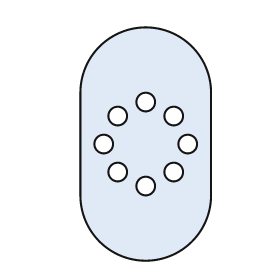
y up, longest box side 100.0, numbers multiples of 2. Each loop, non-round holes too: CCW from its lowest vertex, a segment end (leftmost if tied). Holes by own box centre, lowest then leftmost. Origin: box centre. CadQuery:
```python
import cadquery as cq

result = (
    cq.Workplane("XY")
    .moveTo(-28.0, -22.0)
    .threePointArc((0.0, -50.0), (28.0, -22.0))
    .lineTo(28.0, 22.0)
    .threePointArc((0.0, 50.0), (-28.0, 22.0))
    .close()
    .moveTo(0.0, -18.0)
    .circle(4.0)
    .moveTo(-12.0, -12.0)
    .circle(4.0)
    .moveTo(12.0, -12.0)
    .circle(4.0)
    .moveTo(-18.0, 0.0)
    .circle(4.0)
    .moveTo(18.0, 0.0)
    .circle(4.0)
    .moveTo(-12.0, 12.0)
    .circle(4.0)
    .moveTo(12.0, 12.0)
    .circle(4.0)
    .moveTo(0.0, 18.0)
    .circle(4.0)
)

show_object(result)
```